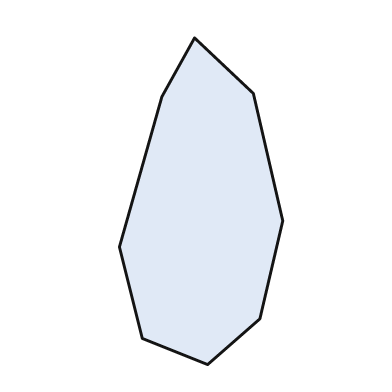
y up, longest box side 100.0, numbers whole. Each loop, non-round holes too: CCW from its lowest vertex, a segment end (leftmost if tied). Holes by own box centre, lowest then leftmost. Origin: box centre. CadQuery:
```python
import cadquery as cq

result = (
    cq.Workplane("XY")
    .moveTo(2.0, -50.0)
    .lineTo(18.0, -36.0)
    .lineTo(25.0, -6.0)
    .lineTo(16.0, 33.0)
    .lineTo(-2.0, 50.0)
    .lineTo(-12.0, 32.0)
    .lineTo(-25.0, -14.0)
    .lineTo(-18.0, -42.0)
    .close()
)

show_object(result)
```